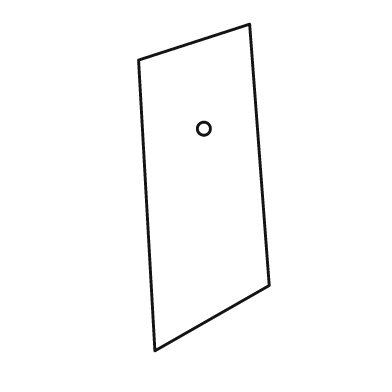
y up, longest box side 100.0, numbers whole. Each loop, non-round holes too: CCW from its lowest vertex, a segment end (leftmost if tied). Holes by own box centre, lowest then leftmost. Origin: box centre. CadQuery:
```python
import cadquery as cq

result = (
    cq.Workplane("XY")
    .moveTo(-15.0, -50.0)
    .lineTo(20.0, -30.0)
    .lineTo(14.0, 50.0)
    .lineTo(-20.0, 39.0)
    .close()
    .moveTo(0.0, 18.0)
    .circle(2.0)
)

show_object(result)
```